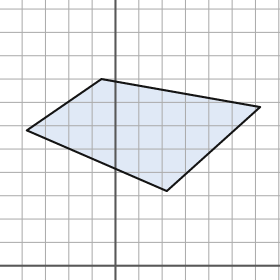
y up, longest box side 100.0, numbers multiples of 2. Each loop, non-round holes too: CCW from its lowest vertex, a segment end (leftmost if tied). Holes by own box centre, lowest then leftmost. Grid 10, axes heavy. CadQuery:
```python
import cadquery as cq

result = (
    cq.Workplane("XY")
    .moveTo(22.0, 32.0)
    .lineTo(62.0, 68.0)
    .lineTo(-6.0, 80.0)
    .lineTo(-38.0, 58.0)
    .close()
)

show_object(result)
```